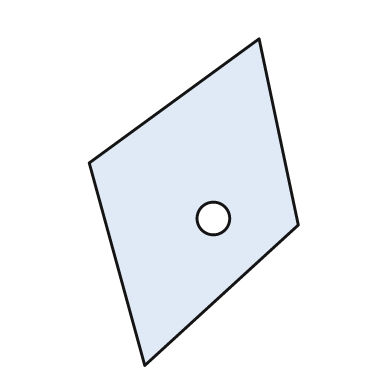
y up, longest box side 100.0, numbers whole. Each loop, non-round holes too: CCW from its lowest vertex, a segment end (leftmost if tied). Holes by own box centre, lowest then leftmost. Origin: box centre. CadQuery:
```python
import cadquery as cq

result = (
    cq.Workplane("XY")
    .moveTo(-15.0, -50.0)
    .lineTo(32.0, -7.0)
    .lineTo(20.0, 50.0)
    .lineTo(-32.0, 12.0)
    .close()
    .moveTo(6.0, -5.0)
    .circle(5.0)
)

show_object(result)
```